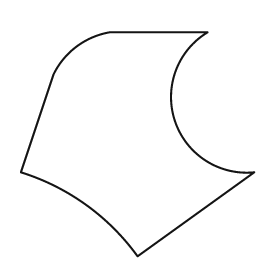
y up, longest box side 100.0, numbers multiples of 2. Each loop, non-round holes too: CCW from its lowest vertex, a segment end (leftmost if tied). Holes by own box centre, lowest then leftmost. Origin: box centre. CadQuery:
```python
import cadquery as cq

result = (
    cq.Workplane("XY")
    .moveTo(0.0, -48.0)
    .lineTo(50.0, -12.0)
    .threePointArc((16.0, 10.0), (30.0, 48.0))
    .lineTo(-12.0, 48.0)
    .threePointArc((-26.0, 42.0), (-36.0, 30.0))
    .lineTo(-50.0, -12.0)
    .threePointArc((-22.0, -26.0), (0.0, -48.0))
    .close()
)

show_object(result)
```